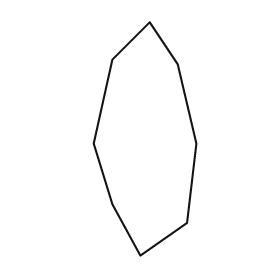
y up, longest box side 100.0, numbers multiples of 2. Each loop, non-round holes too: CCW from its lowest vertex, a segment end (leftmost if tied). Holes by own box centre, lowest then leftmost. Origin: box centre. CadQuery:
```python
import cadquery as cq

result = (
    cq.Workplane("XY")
    .moveTo(-2.0, -50.0)
    .lineTo(18.0, -36.0)
    .lineTo(22.0, -2.0)
    .lineTo(14.0, 32.0)
    .lineTo(2.0, 50.0)
    .lineTo(-14.0, 34.0)
    .lineTo(-22.0, -2.0)
    .lineTo(-14.0, -28.0)
    .close()
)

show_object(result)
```